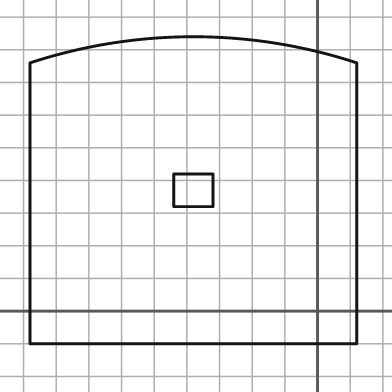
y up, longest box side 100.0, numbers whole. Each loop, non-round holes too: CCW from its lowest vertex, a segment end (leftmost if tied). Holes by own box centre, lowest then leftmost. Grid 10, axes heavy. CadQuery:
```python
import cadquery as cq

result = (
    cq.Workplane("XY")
    .moveTo(-88.0, -10.0)
    .lineTo(12.0, -10.0)
    .lineTo(12.0, 76.0)
    .threePointArc((-38.0, 84.0), (-88.0, 76.0))
    .close()
    .moveTo(-44.0, 32.0)
    .lineTo(-32.0, 32.0)
    .lineTo(-32.0, 42.0)
    .lineTo(-44.0, 42.0)
    .close()
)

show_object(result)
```